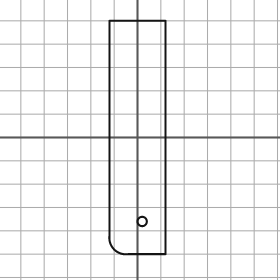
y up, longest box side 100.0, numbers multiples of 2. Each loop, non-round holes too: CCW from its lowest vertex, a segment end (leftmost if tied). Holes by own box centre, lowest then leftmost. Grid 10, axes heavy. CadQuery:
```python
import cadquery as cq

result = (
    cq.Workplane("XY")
    .moveTo(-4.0, -50.0)
    .lineTo(12.0, -50.0)
    .lineTo(12.0, 50.0)
    .lineTo(-12.0, 50.0)
    .lineTo(-12.0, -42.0)
    .threePointArc((-10.0, -48.0), (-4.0, -50.0))
    .close()
    .moveTo(2.0, -36.0)
    .circle(2.0)
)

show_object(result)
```